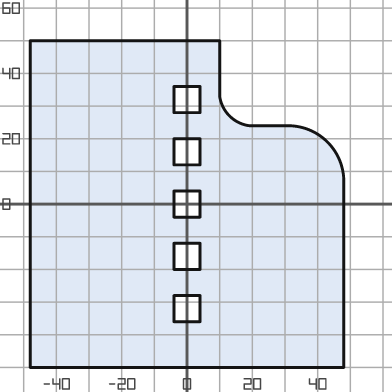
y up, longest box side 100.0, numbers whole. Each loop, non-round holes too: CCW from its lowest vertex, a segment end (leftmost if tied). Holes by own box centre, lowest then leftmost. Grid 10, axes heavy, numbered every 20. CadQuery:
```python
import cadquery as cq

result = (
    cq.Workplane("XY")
    .moveTo(-48.0, -50.0)
    .lineTo(48.0, -50.0)
    .lineTo(48.0, 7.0)
    .threePointArc((43.0, 19.0), (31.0, 24.0))
    .lineTo(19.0, 24.0)
    .threePointArc((13.0, 27.0), (10.0, 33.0))
    .lineTo(10.0, 50.0)
    .lineTo(-48.0, 50.0)
    .close()
    .moveTo(-4.0, -36.0)
    .lineTo(4.0, -36.0)
    .lineTo(4.0, -28.0)
    .lineTo(-4.0, -28.0)
    .close()
    .moveTo(-4.0, -20.0)
    .lineTo(4.0, -20.0)
    .lineTo(4.0, -12.0)
    .lineTo(-4.0, -12.0)
    .close()
    .moveTo(-4.0, -4.0)
    .lineTo(4.0, -4.0)
    .lineTo(4.0, 4.0)
    .lineTo(-4.0, 4.0)
    .close()
    .moveTo(-4.0, 12.0)
    .lineTo(4.0, 12.0)
    .lineTo(4.0, 20.0)
    .lineTo(-4.0, 20.0)
    .close()
    .moveTo(-4.0, 28.0)
    .lineTo(4.0, 28.0)
    .lineTo(4.0, 36.0)
    .lineTo(-4.0, 36.0)
    .close()
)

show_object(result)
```